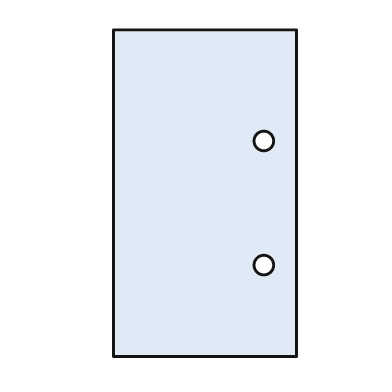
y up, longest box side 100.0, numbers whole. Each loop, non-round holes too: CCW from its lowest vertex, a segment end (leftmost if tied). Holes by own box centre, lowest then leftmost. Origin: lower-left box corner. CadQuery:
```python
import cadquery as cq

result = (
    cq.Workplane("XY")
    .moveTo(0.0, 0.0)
    .lineTo(56.0, 0.0)
    .lineTo(56.0, 100.0)
    .lineTo(0.0, 100.0)
    .close()
    .moveTo(46.0, 28.0)
    .circle(3.0)
    .moveTo(46.0, 66.0)
    .circle(3.0)
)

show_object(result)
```